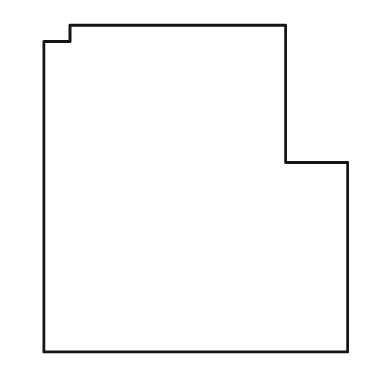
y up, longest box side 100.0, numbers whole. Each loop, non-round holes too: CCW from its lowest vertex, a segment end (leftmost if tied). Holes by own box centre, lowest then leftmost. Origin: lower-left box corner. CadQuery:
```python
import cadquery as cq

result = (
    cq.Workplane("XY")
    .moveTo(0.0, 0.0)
    .lineTo(93.0, 0.0)
    .lineTo(93.0, 58.0)
    .lineTo(74.0, 58.0)
    .lineTo(74.0, 100.0)
    .lineTo(8.0, 100.0)
    .lineTo(8.0, 95.0)
    .lineTo(0.0, 95.0)
    .close()
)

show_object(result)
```